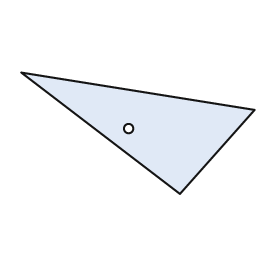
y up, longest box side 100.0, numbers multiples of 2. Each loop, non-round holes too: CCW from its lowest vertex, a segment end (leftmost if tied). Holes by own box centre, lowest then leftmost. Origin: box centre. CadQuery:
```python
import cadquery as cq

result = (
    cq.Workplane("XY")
    .moveTo(18.0, -26.0)
    .lineTo(50.0, 10.0)
    .lineTo(-50.0, 26.0)
    .close()
    .moveTo(-4.0, 2.0)
    .circle(2.0)
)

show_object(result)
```